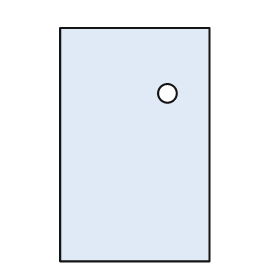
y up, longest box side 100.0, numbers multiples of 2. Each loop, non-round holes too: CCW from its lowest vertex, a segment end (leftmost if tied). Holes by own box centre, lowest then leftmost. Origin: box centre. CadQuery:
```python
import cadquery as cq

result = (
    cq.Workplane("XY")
    .moveTo(-32.0, -50.0)
    .lineTo(32.0, -50.0)
    .lineTo(32.0, 50.0)
    .lineTo(-32.0, 50.0)
    .close()
    .moveTo(14.0, 22.0)
    .circle(4.0)
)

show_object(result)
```